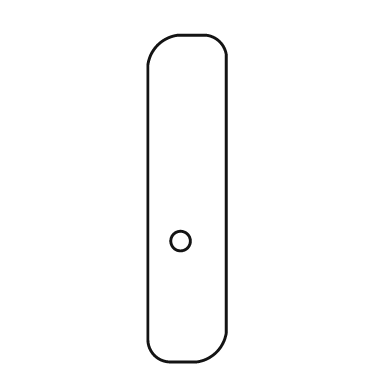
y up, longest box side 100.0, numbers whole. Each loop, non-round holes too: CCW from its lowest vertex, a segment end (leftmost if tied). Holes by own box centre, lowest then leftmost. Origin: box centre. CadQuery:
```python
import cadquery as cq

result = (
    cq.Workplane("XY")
    .moveTo(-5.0, -50.0)
    .lineTo(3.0, -50.0)
    .threePointArc((9.0, -47.0), (12.0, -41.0))
    .lineTo(12.0, 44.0)
    .threePointArc((10.0, 48.0), (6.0, 50.0))
    .lineTo(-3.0, 50.0)
    .threePointArc((-9.0, 47.0), (-12.0, 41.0))
    .lineTo(-12.0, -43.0)
    .threePointArc((-10.0, -48.0), (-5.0, -50.0))
    .close()
    .moveTo(-2.0, -13.0)
    .circle(3.0)
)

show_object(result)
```